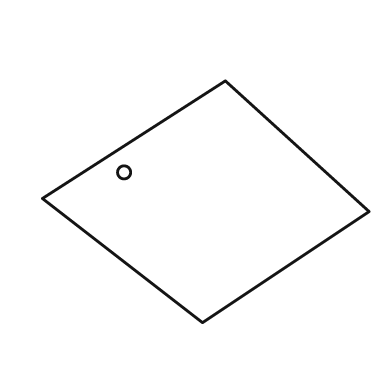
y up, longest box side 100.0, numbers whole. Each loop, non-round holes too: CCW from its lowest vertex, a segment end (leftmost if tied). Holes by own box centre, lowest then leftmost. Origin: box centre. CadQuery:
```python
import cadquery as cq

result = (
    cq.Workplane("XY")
    .moveTo(-1.0, -37.0)
    .lineTo(50.0, -3.0)
    .lineTo(6.0, 37.0)
    .lineTo(-50.0, 1.0)
    .close()
    .moveTo(-25.0, 9.0)
    .circle(2.0)
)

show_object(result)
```